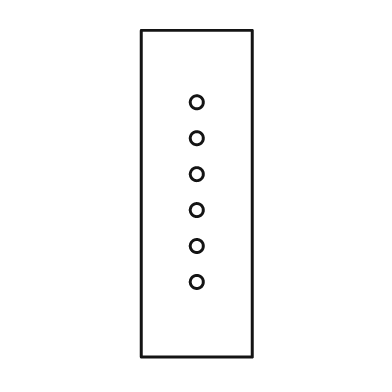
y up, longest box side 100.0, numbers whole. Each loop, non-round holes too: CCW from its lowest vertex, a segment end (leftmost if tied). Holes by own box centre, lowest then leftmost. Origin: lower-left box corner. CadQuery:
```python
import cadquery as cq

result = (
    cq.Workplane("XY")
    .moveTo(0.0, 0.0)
    .lineTo(34.0, 0.0)
    .lineTo(34.0, 100.0)
    .lineTo(0.0, 100.0)
    .close()
    .moveTo(17.0, 23.0)
    .circle(2.0)
    .moveTo(17.0, 34.0)
    .circle(2.0)
    .moveTo(17.0, 45.0)
    .circle(2.0)
    .moveTo(17.0, 56.0)
    .circle(2.0)
    .moveTo(17.0, 67.0)
    .circle(2.0)
    .moveTo(17.0, 78.0)
    .circle(2.0)
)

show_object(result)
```